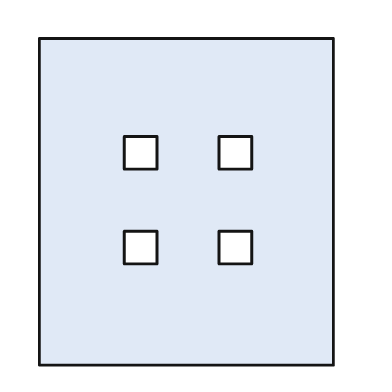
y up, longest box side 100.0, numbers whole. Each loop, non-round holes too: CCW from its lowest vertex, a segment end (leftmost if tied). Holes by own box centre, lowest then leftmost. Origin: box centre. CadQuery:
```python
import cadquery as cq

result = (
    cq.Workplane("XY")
    .moveTo(-45.0, -50.0)
    .lineTo(45.0, -50.0)
    .lineTo(45.0, 50.0)
    .lineTo(-45.0, 50.0)
    .close()
    .moveTo(-19.0, -19.0)
    .lineTo(-9.0, -19.0)
    .lineTo(-9.0, -9.0)
    .lineTo(-19.0, -9.0)
    .close()
    .moveTo(10.0, -19.0)
    .lineTo(20.0, -19.0)
    .lineTo(20.0, -9.0)
    .lineTo(10.0, -9.0)
    .close()
    .moveTo(-19.0, 10.0)
    .lineTo(-9.0, 10.0)
    .lineTo(-9.0, 20.0)
    .lineTo(-19.0, 20.0)
    .close()
    .moveTo(10.0, 10.0)
    .lineTo(20.0, 10.0)
    .lineTo(20.0, 20.0)
    .lineTo(10.0, 20.0)
    .close()
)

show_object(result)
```